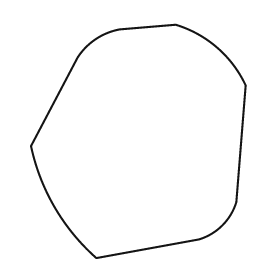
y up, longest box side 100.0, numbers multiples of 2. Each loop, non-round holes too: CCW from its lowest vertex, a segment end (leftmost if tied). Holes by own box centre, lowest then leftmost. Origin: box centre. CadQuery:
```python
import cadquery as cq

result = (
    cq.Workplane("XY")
    .moveTo(-18.0, -50.0)
    .lineTo(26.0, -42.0)
    .threePointArc((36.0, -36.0), (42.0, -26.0))
    .lineTo(46.0, 24.0)
    .threePointArc((34.0, 40.0), (16.0, 50.0))
    .lineTo(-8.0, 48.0)
    .threePointArc((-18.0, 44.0), (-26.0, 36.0))
    .lineTo(-46.0, -2.0)
    .threePointArc((-36.0, -28.0), (-18.0, -50.0))
    .close()
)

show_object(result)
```